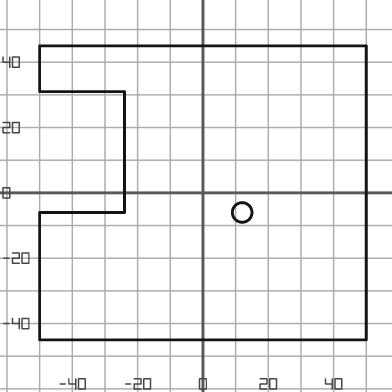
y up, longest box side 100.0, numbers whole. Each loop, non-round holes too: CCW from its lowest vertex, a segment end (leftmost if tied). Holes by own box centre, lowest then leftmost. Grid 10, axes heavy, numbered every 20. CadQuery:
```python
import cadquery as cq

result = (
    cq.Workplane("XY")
    .moveTo(-50.0, -45.0)
    .lineTo(50.0, -45.0)
    .lineTo(50.0, 45.0)
    .lineTo(-50.0, 45.0)
    .lineTo(-50.0, 31.0)
    .lineTo(-24.0, 31.0)
    .lineTo(-24.0, -6.0)
    .lineTo(-50.0, -6.0)
    .close()
    .moveTo(12.0, -6.0)
    .circle(3.0)
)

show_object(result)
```